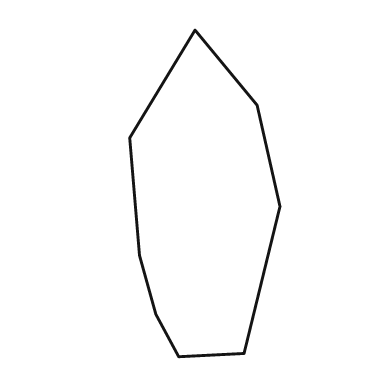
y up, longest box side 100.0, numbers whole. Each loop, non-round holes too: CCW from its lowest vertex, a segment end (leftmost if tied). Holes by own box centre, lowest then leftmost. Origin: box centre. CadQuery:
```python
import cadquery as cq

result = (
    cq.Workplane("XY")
    .moveTo(-8.0, -50.0)
    .lineTo(12.0, -49.0)
    .lineTo(23.0, -4.0)
    .lineTo(16.0, 27.0)
    .lineTo(-3.0, 50.0)
    .lineTo(-23.0, 17.0)
    .lineTo(-20.0, -19.0)
    .lineTo(-15.0, -37.0)
    .close()
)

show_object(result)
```